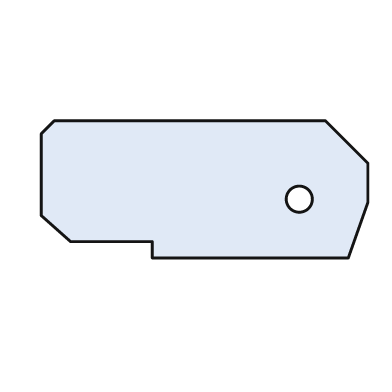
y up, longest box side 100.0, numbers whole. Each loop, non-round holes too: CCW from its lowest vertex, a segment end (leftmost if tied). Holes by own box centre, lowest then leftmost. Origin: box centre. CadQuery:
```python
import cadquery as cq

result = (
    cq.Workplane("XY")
    .moveTo(-16.0, -21.0)
    .lineTo(44.0, -21.0)
    .lineTo(50.0, -4.0)
    .lineTo(50.0, 8.0)
    .lineTo(37.0, 21.0)
    .lineTo(-46.0, 21.0)
    .lineTo(-50.0, 17.0)
    .lineTo(-50.0, -8.0)
    .lineTo(-41.0, -16.0)
    .lineTo(-16.0, -16.0)
    .close()
    .moveTo(29.0, -3.0)
    .circle(4.0)
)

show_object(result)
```